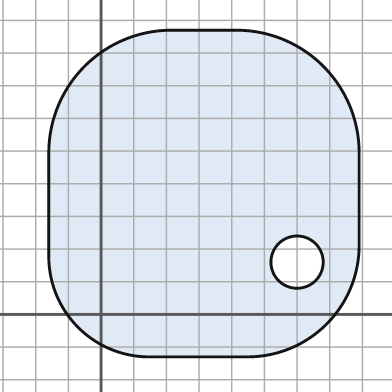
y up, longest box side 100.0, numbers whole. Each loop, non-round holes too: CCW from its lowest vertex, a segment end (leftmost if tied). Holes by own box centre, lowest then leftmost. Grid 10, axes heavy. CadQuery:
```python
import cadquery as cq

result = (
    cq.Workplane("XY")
    .moveTo(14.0, -13.0)
    .lineTo(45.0, -13.0)
    .threePointArc((69.0, -3.0), (79.0, 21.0))
    .lineTo(79.0, 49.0)
    .threePointArc((68.0, 76.0), (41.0, 87.0))
    .lineTo(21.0, 87.0)
    .threePointArc((-5.0, 76.0), (-16.0, 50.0))
    .lineTo(-16.0, 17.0)
    .threePointArc((-7.0, -4.0), (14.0, -13.0))
    .close()
    .moveTo(60.0, 16.0)
    .circle(8.0)
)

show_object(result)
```